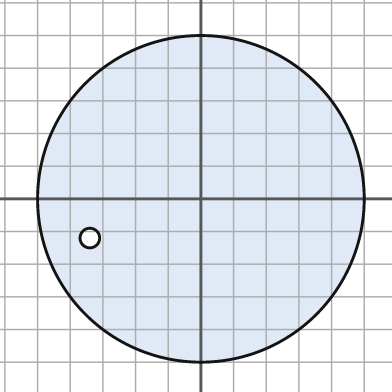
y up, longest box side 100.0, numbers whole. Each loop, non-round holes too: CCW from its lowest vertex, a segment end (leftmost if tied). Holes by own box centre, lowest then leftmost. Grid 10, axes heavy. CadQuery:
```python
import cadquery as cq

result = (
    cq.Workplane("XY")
    .moveTo(0.0, 0.0)
    .circle(50.0)
    .moveTo(-34.0, -12.0)
    .circle(3.0)
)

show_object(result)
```